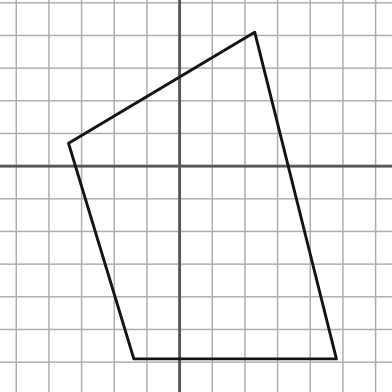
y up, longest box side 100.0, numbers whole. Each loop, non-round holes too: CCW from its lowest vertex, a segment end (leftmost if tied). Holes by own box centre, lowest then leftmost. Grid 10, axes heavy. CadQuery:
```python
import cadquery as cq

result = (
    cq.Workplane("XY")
    .moveTo(-14.0, -59.0)
    .lineTo(48.0, -59.0)
    .lineTo(23.0, 41.0)
    .lineTo(-34.0, 7.0)
    .close()
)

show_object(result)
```